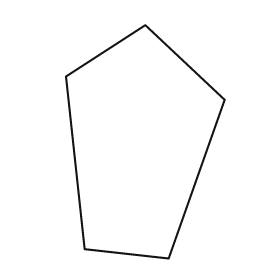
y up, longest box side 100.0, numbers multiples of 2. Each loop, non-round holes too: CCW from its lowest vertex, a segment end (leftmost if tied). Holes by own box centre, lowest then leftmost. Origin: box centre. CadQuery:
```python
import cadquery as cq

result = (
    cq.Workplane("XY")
    .moveTo(10.0, -50.0)
    .lineTo(34.0, 18.0)
    .lineTo(0.0, 50.0)
    .lineTo(-34.0, 28.0)
    .lineTo(-26.0, -46.0)
    .close()
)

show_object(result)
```